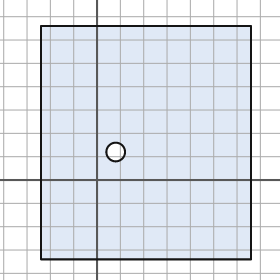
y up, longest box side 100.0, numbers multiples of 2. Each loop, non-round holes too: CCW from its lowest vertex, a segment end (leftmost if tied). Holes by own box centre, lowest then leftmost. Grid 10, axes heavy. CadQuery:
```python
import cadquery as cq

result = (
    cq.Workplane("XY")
    .moveTo(-24.0, -34.0)
    .lineTo(66.0, -34.0)
    .lineTo(66.0, 66.0)
    .lineTo(-24.0, 66.0)
    .close()
    .moveTo(8.0, 12.0)
    .circle(4.0)
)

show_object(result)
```